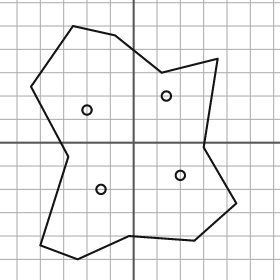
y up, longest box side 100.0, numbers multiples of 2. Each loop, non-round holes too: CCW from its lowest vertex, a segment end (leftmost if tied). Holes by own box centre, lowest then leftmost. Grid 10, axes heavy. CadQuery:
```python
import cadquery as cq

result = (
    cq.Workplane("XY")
    .moveTo(-24.0, -50.0)
    .lineTo(-2.0, -40.0)
    .lineTo(26.0, -42.0)
    .lineTo(44.0, -26.0)
    .lineTo(30.0, -2.0)
    .lineTo(36.0, 36.0)
    .lineTo(12.0, 30.0)
    .lineTo(-8.0, 46.0)
    .lineTo(-26.0, 50.0)
    .lineTo(-44.0, 24.0)
    .lineTo(-28.0, -6.0)
    .lineTo(-40.0, -44.0)
    .close()
    .moveTo(-14.0, -20.0)
    .circle(2.0)
    .moveTo(20.0, -14.0)
    .circle(2.0)
    .moveTo(-20.0, 14.0)
    .circle(2.0)
    .moveTo(14.0, 20.0)
    .circle(2.0)
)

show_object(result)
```